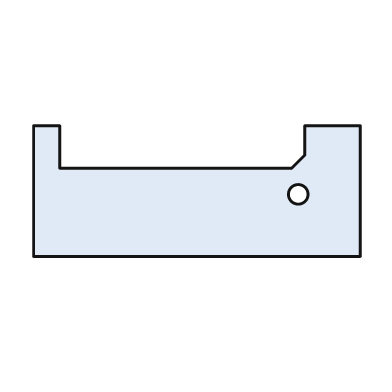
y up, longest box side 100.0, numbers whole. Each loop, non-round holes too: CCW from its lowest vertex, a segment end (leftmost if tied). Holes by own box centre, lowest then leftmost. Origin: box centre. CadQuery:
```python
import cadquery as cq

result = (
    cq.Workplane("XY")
    .moveTo(-50.0, -20.0)
    .lineTo(50.0, -20.0)
    .lineTo(50.0, 20.0)
    .lineTo(33.0, 20.0)
    .lineTo(33.0, 11.0)
    .lineTo(29.0, 7.0)
    .lineTo(-42.0, 7.0)
    .lineTo(-42.0, 20.0)
    .lineTo(-50.0, 20.0)
    .close()
    .moveTo(31.0, -1.0)
    .circle(3.0)
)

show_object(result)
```